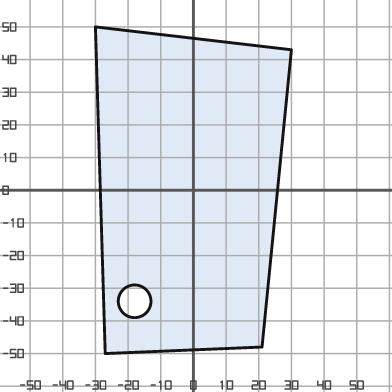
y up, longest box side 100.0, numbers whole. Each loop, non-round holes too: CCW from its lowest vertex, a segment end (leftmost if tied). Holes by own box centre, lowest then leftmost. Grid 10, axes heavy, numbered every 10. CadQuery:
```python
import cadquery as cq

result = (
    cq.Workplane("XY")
    .moveTo(-27.0, -50.0)
    .lineTo(21.0, -48.0)
    .lineTo(30.0, 43.0)
    .lineTo(-30.0, 50.0)
    .close()
    .moveTo(-18.0, -34.0)
    .circle(5.0)
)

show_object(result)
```